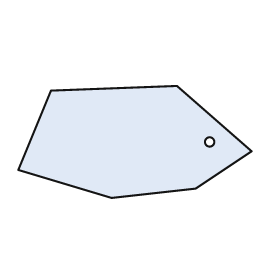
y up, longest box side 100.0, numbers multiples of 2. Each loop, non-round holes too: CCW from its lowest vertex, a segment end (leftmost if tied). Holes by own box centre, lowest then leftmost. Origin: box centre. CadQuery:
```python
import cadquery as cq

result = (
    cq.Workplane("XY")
    .moveTo(-10.0, -24.0)
    .lineTo(26.0, -20.0)
    .lineTo(50.0, -4.0)
    .lineTo(18.0, 24.0)
    .lineTo(-36.0, 22.0)
    .lineTo(-50.0, -12.0)
    .close()
    .moveTo(32.0, 0.0)
    .circle(2.0)
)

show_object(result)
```